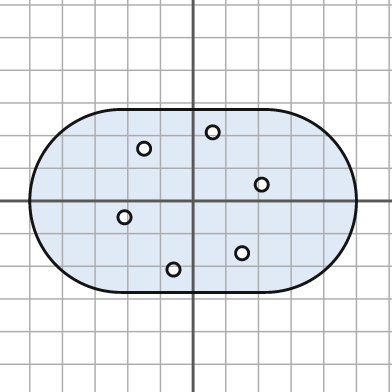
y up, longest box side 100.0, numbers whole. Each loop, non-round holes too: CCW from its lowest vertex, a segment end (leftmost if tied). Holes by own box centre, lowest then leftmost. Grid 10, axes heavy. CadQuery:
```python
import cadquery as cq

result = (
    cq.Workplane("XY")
    .moveTo(-22.0, -28.0)
    .lineTo(22.0, -28.0)
    .threePointArc((50.0, 0.0), (22.0, 28.0))
    .lineTo(-22.0, 28.0)
    .threePointArc((-50.0, 0.0), (-22.0, -28.0))
    .close()
    .moveTo(-6.0, -21.0)
    .circle(2.0)
    .moveTo(15.0, -16.0)
    .circle(2.0)
    .moveTo(-21.0, -5.0)
    .circle(2.0)
    .moveTo(21.0, 5.0)
    .circle(2.0)
    .moveTo(-15.0, 16.0)
    .circle(2.0)
    .moveTo(6.0, 21.0)
    .circle(2.0)
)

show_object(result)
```